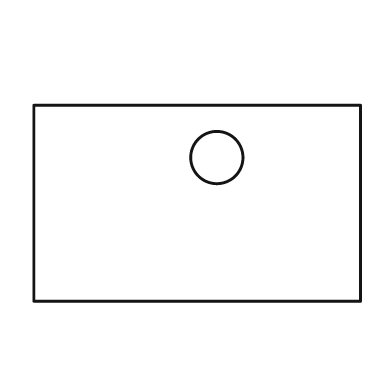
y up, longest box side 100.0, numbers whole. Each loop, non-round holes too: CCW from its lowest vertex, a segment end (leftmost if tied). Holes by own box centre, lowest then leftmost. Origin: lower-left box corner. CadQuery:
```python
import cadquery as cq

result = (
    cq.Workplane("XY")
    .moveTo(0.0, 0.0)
    .lineTo(100.0, 0.0)
    .lineTo(100.0, 60.0)
    .lineTo(0.0, 60.0)
    .close()
    .moveTo(56.0, 44.0)
    .circle(8.0)
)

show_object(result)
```